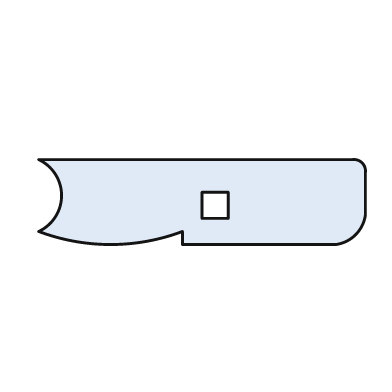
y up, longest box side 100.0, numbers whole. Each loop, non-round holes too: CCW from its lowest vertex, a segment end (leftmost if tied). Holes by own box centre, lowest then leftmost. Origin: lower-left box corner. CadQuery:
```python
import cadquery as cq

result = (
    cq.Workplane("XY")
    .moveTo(44.0, 0.0)
    .lineTo(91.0, 0.0)
    .threePointArc((97.0, 3.0), (100.0, 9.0))
    .lineTo(100.0, 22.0)
    .threePointArc((99.0, 25.0), (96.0, 26.0))
    .lineTo(0.0, 26.0)
    .threePointArc((7.0, 15.0), (0.0, 4.0))
    .threePointArc((22.0, 0.0), (44.0, 4.0))
    .close()
    .moveTo(50.0, 8.0)
    .lineTo(58.0, 8.0)
    .lineTo(58.0, 16.0)
    .lineTo(50.0, 16.0)
    .close()
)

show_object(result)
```